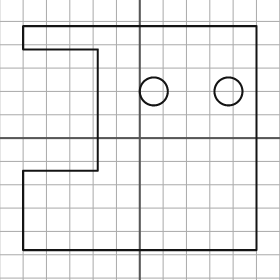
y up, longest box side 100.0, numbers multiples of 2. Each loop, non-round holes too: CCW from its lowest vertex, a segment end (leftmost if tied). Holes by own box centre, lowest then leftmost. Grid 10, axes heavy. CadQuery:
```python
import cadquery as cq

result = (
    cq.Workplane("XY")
    .moveTo(-50.0, -48.0)
    .lineTo(50.0, -48.0)
    .lineTo(50.0, 48.0)
    .lineTo(-50.0, 48.0)
    .lineTo(-50.0, 38.0)
    .lineTo(-18.0, 38.0)
    .lineTo(-18.0, -14.0)
    .lineTo(-50.0, -14.0)
    .close()
    .moveTo(6.0, 20.0)
    .circle(6.0)
    .moveTo(38.0, 20.0)
    .circle(6.0)
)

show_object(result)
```